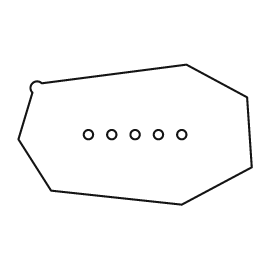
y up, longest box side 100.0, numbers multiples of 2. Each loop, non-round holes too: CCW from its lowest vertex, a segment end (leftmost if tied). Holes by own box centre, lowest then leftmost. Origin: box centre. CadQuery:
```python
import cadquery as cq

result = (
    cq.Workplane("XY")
    .moveTo(20.0, -30.0)
    .lineTo(50.0, -14.0)
    .lineTo(48.0, 16.0)
    .lineTo(22.0, 30.0)
    .lineTo(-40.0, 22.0)
    .threePointArc((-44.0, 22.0), (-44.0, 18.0))
    .lineTo(-50.0, -2.0)
    .lineTo(-36.0, -24.0)
    .close()
    .moveTo(-20.0, 0.0)
    .circle(2.0)
    .moveTo(-10.0, 0.0)
    .circle(2.0)
    .moveTo(0.0, 0.0)
    .circle(2.0)
    .moveTo(10.0, 0.0)
    .circle(2.0)
    .moveTo(20.0, 0.0)
    .circle(2.0)
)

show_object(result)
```